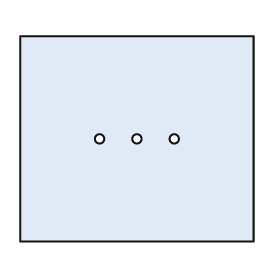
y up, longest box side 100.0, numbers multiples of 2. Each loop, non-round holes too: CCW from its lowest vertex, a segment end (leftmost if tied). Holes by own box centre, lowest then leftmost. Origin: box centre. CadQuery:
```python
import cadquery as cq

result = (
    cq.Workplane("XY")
    .moveTo(-50.0, -44.0)
    .lineTo(50.0, -44.0)
    .lineTo(50.0, 44.0)
    .lineTo(-50.0, 44.0)
    .close()
    .moveTo(-16.0, 0.0)
    .circle(2.0)
    .moveTo(0.0, 0.0)
    .circle(2.0)
    .moveTo(16.0, 0.0)
    .circle(2.0)
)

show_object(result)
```